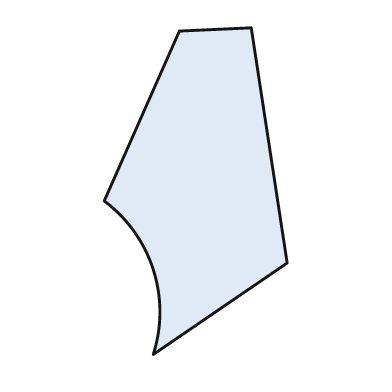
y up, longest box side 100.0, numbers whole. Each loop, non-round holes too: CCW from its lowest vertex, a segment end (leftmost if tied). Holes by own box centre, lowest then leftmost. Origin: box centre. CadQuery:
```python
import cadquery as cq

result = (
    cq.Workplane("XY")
    .moveTo(-13.0, -50.0)
    .lineTo(28.0, -22.0)
    .lineTo(17.0, 50.0)
    .lineTo(-5.0, 49.0)
    .lineTo(-28.0, -3.0)
    .threePointArc((-13.0, -24.0), (-13.0, -50.0))
    .close()
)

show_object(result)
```